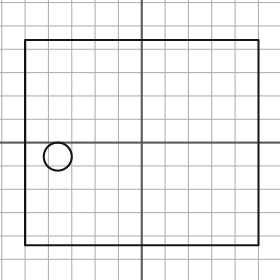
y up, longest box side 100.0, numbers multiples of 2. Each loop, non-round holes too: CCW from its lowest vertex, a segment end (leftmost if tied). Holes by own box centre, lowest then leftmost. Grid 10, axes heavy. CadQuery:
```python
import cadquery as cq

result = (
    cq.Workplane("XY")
    .moveTo(-50.0, -44.0)
    .lineTo(50.0, -44.0)
    .lineTo(50.0, 44.0)
    .lineTo(-50.0, 44.0)
    .close()
    .moveTo(-36.0, -6.0)
    .circle(6.0)
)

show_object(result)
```